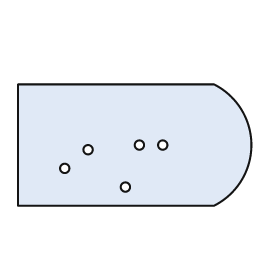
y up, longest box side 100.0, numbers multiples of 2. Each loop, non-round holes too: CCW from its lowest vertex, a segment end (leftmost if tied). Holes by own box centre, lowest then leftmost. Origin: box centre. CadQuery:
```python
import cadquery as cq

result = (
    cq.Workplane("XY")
    .moveTo(-50.0, -26.0)
    .lineTo(34.0, -26.0)
    .threePointArc((50.0, 0.0), (34.0, 26.0))
    .lineTo(-50.0, 26.0)
    .close()
    .moveTo(-4.0, -18.0)
    .circle(2.0)
    .moveTo(-30.0, -10.0)
    .circle(2.0)
    .moveTo(-20.0, -2.0)
    .circle(2.0)
    .moveTo(2.0, 0.0)
    .circle(2.0)
    .moveTo(12.0, 0.0)
    .circle(2.0)
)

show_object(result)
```